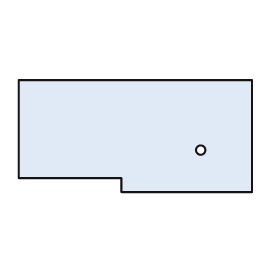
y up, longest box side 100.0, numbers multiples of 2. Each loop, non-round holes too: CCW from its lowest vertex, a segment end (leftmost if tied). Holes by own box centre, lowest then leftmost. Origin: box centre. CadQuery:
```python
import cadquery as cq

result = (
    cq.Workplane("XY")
    .moveTo(-6.0, -24.0)
    .lineTo(50.0, -24.0)
    .lineTo(50.0, 24.0)
    .lineTo(-50.0, 24.0)
    .lineTo(-50.0, -18.0)
    .lineTo(-6.0, -18.0)
    .close()
    .moveTo(28.0, -6.0)
    .circle(2.0)
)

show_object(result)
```